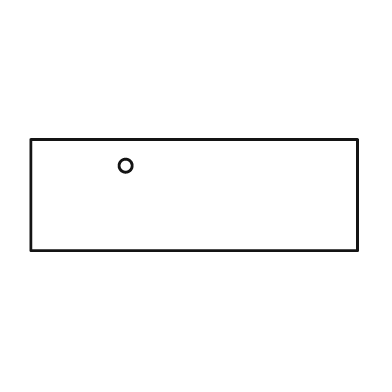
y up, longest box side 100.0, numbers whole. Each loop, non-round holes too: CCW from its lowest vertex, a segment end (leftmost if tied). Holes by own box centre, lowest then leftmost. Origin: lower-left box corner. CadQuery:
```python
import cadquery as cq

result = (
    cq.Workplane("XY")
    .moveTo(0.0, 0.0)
    .lineTo(100.0, 0.0)
    .lineTo(100.0, 34.0)
    .lineTo(0.0, 34.0)
    .close()
    .moveTo(29.0, 26.0)
    .circle(2.0)
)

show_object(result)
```